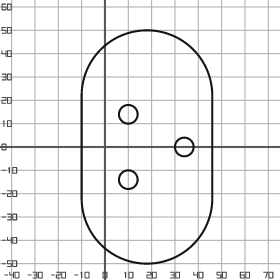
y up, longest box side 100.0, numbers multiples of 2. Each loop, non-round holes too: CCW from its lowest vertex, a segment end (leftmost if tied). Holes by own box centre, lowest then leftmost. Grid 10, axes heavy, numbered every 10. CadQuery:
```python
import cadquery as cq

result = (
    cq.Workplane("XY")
    .moveTo(-10.0, -22.0)
    .threePointArc((18.0, -50.0), (46.0, -22.0))
    .lineTo(46.0, 22.0)
    .threePointArc((18.0, 50.0), (-10.0, 22.0))
    .close()
    .moveTo(10.0, -14.0)
    .circle(4.0)
    .moveTo(34.0, 0.0)
    .circle(4.0)
    .moveTo(10.0, 14.0)
    .circle(4.0)
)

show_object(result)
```